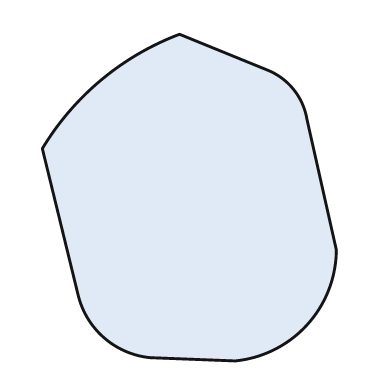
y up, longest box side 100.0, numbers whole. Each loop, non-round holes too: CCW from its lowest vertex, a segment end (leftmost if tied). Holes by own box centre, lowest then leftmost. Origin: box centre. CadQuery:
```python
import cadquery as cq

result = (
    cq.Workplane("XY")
    .moveTo(14.0, -50.0)
    .threePointArc((36.0, -39.0), (45.0, -16.0))
    .lineTo(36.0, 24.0)
    .threePointArc((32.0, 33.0), (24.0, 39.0))
    .lineTo(-3.0, 50.0)
    .threePointArc((-27.0, 36.0), (-45.0, 15.0))
    .lineTo(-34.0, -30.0)
    .threePointArc((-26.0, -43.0), (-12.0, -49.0))
    .close()
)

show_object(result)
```